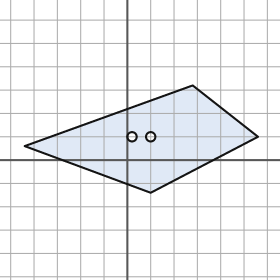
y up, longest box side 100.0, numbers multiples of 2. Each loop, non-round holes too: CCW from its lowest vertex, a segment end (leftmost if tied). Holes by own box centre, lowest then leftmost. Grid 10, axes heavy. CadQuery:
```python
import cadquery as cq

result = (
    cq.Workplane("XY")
    .moveTo(10.0, -14.0)
    .lineTo(56.0, 10.0)
    .lineTo(28.0, 32.0)
    .lineTo(-44.0, 6.0)
    .close()
    .moveTo(2.0, 10.0)
    .circle(2.0)
    .moveTo(10.0, 10.0)
    .circle(2.0)
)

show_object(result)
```